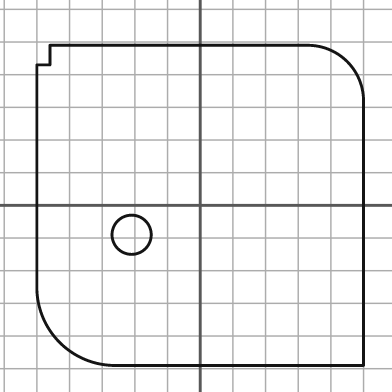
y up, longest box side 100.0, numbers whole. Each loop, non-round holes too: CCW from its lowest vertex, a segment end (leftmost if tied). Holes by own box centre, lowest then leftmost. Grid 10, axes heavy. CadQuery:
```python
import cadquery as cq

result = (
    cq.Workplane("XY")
    .moveTo(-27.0, -49.0)
    .lineTo(50.0, -49.0)
    .lineTo(50.0, 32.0)
    .threePointArc((45.0, 44.0), (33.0, 49.0))
    .lineTo(-46.0, 49.0)
    .lineTo(-46.0, 43.0)
    .lineTo(-50.0, 43.0)
    .lineTo(-50.0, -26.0)
    .threePointArc((-43.0, -42.0), (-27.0, -49.0))
    .close()
    .moveTo(-21.0, -9.0)
    .circle(6.0)
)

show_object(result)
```